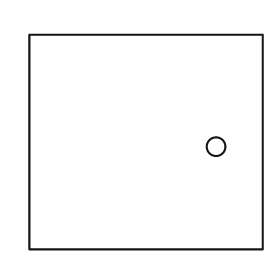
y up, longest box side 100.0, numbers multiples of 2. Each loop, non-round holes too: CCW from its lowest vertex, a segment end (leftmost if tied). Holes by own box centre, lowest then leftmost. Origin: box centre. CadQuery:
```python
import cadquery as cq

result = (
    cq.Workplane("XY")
    .moveTo(-50.0, -46.0)
    .lineTo(50.0, -46.0)
    .lineTo(50.0, 46.0)
    .lineTo(-50.0, 46.0)
    .close()
    .moveTo(30.0, -2.0)
    .circle(4.0)
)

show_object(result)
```